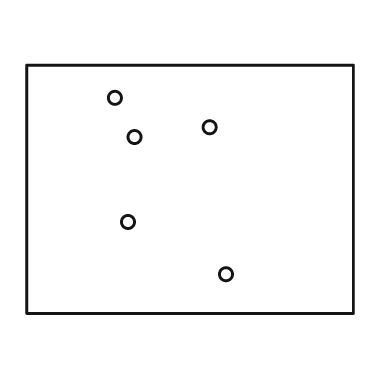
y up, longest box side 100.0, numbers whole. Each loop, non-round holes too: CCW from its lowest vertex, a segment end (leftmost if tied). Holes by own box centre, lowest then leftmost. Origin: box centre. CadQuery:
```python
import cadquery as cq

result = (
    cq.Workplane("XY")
    .moveTo(-50.0, -38.0)
    .lineTo(50.0, -38.0)
    .lineTo(50.0, 38.0)
    .lineTo(-50.0, 38.0)
    .close()
    .moveTo(11.0, -26.0)
    .circle(2.0)
    .moveTo(-19.0, -10.0)
    .circle(2.0)
    .moveTo(-17.0, 16.0)
    .circle(2.0)
    .moveTo(6.0, 19.0)
    .circle(2.0)
    .moveTo(-23.0, 28.0)
    .circle(2.0)
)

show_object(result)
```